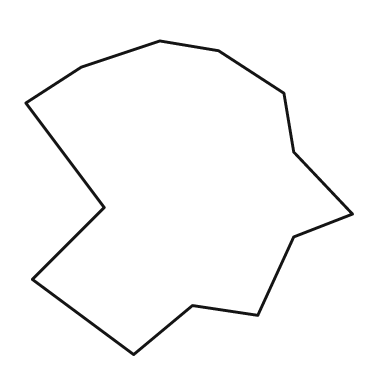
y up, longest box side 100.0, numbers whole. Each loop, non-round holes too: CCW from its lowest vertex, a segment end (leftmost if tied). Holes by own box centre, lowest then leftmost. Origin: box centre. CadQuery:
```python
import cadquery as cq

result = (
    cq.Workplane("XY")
    .moveTo(-17.0, -48.0)
    .lineTo(1.0, -33.0)
    .lineTo(21.0, -36.0)
    .lineTo(32.0, -12.0)
    .lineTo(50.0, -5.0)
    .lineTo(32.0, 14.0)
    .lineTo(29.0, 32.0)
    .lineTo(9.0, 45.0)
    .lineTo(-9.0, 48.0)
    .lineTo(-33.0, 40.0)
    .lineTo(-50.0, 29.0)
    .lineTo(-26.0, -3.0)
    .lineTo(-48.0, -25.0)
    .close()
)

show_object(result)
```